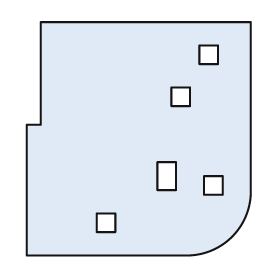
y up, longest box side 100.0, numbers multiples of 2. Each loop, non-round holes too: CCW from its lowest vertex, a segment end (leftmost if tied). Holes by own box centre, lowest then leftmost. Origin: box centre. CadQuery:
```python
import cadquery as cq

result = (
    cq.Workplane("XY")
    .moveTo(-48.0, -50.0)
    .lineTo(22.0, -50.0)
    .threePointArc((40.0, -42.0), (48.0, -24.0))
    .lineTo(48.0, 50.0)
    .lineTo(-42.0, 50.0)
    .lineTo(-42.0, 6.0)
    .lineTo(-48.0, 6.0)
    .close()
    .moveTo(-18.0, -40.0)
    .lineTo(-10.0, -40.0)
    .lineTo(-10.0, -32.0)
    .lineTo(-18.0, -32.0)
    .close()
    .moveTo(28.0, -24.0)
    .lineTo(36.0, -24.0)
    .lineTo(36.0, -16.0)
    .lineTo(28.0, -16.0)
    .close()
    .moveTo(8.0, -22.0)
    .lineTo(16.0, -22.0)
    .lineTo(16.0, -10.0)
    .lineTo(8.0, -10.0)
    .close()
    .moveTo(14.0, 14.0)
    .lineTo(22.0, 14.0)
    .lineTo(22.0, 22.0)
    .lineTo(14.0, 22.0)
    .close()
    .moveTo(26.0, 32.0)
    .lineTo(34.0, 32.0)
    .lineTo(34.0, 40.0)
    .lineTo(26.0, 40.0)
    .close()
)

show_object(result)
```